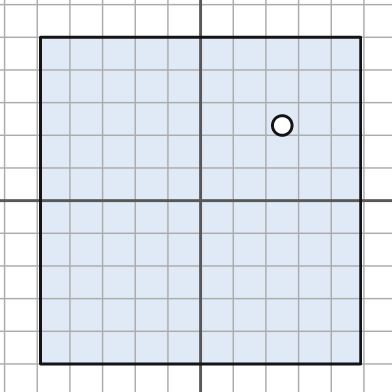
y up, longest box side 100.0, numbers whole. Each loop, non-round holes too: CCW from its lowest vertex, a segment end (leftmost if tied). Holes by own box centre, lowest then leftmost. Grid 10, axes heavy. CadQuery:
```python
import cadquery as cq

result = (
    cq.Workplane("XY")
    .moveTo(-49.0, -50.0)
    .lineTo(49.0, -50.0)
    .lineTo(49.0, 50.0)
    .lineTo(-49.0, 50.0)
    .close()
    .moveTo(25.0, 23.0)
    .circle(3.0)
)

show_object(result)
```